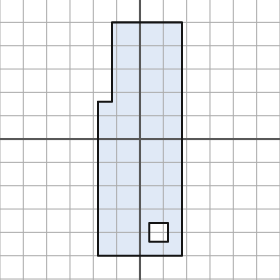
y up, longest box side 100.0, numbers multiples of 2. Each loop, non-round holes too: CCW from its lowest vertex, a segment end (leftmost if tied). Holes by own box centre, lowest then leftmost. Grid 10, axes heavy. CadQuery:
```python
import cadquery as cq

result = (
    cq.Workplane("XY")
    .moveTo(-18.0, -50.0)
    .lineTo(18.0, -50.0)
    .lineTo(18.0, 50.0)
    .lineTo(-12.0, 50.0)
    .lineTo(-12.0, 16.0)
    .lineTo(-18.0, 16.0)
    .close()
    .moveTo(4.0, -44.0)
    .lineTo(12.0, -44.0)
    .lineTo(12.0, -36.0)
    .lineTo(4.0, -36.0)
    .close()
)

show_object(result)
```